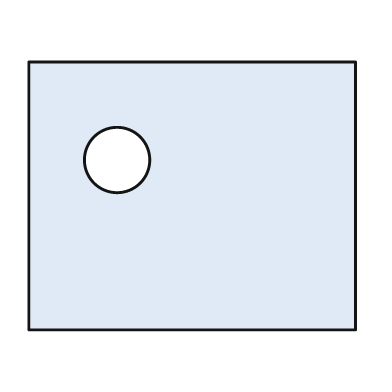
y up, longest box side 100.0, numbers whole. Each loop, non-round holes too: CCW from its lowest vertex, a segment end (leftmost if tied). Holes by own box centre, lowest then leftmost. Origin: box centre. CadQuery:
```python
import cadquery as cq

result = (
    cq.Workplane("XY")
    .moveTo(-50.0, -41.0)
    .lineTo(50.0, -41.0)
    .lineTo(50.0, 41.0)
    .lineTo(-50.0, 41.0)
    .close()
    .moveTo(-23.0, 11.0)
    .circle(10.0)
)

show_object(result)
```